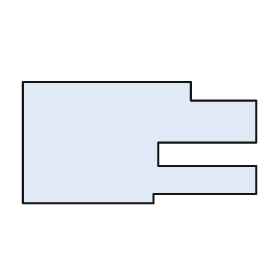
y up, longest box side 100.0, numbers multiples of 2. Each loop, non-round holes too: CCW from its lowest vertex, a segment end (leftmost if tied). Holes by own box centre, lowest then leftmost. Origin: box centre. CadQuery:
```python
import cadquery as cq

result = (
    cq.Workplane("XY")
    .moveTo(-50.0, -26.0)
    .lineTo(6.0, -26.0)
    .lineTo(6.0, -22.0)
    .lineTo(50.0, -22.0)
    .lineTo(50.0, -10.0)
    .lineTo(8.0, -10.0)
    .lineTo(8.0, 0.0)
    .lineTo(50.0, 0.0)
    .lineTo(50.0, 18.0)
    .lineTo(22.0, 18.0)
    .lineTo(22.0, 26.0)
    .lineTo(-50.0, 26.0)
    .close()
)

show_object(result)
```